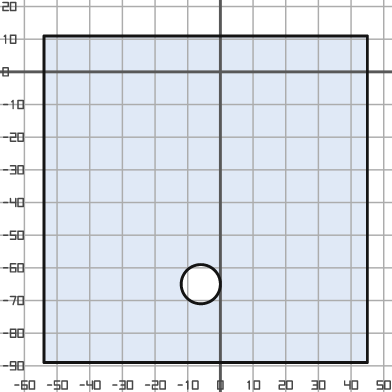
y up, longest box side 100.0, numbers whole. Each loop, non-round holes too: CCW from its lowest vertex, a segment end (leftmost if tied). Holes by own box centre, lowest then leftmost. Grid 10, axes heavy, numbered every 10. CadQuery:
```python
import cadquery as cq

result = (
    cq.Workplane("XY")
    .moveTo(-54.0, -89.0)
    .lineTo(45.0, -89.0)
    .lineTo(45.0, 11.0)
    .lineTo(-54.0, 11.0)
    .close()
    .moveTo(-6.0, -65.0)
    .circle(6.0)
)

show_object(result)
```